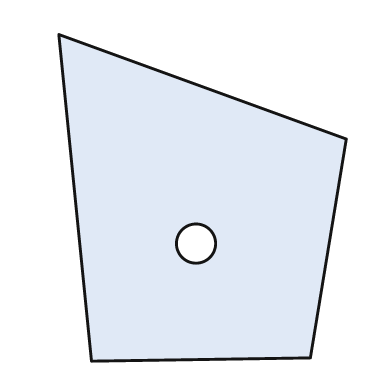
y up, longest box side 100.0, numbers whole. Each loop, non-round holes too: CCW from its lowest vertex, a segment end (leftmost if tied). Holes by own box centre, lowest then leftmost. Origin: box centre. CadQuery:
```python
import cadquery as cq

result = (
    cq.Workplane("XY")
    .moveTo(-34.0, -50.0)
    .lineTo(33.0, -49.0)
    .lineTo(44.0, 18.0)
    .lineTo(-44.0, 50.0)
    .close()
    .moveTo(-2.0, -14.0)
    .circle(6.0)
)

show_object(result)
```